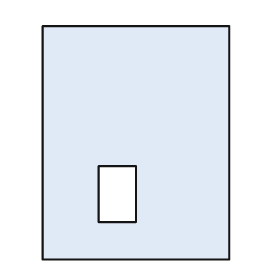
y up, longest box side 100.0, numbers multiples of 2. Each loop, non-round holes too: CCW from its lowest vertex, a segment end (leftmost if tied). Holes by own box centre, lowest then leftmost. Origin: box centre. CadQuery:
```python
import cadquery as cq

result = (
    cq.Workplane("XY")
    .moveTo(-40.0, -50.0)
    .lineTo(40.0, -50.0)
    .lineTo(40.0, 50.0)
    .lineTo(-40.0, 50.0)
    .close()
    .moveTo(-16.0, -34.0)
    .lineTo(0.0, -34.0)
    .lineTo(0.0, -10.0)
    .lineTo(-16.0, -10.0)
    .close()
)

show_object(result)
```